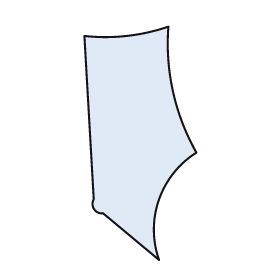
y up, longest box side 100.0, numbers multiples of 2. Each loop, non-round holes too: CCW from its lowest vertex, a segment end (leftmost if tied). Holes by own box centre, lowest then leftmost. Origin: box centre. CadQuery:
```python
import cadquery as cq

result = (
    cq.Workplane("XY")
    .moveTo(8.0, -50.0)
    .threePointArc((8.0, -24.0), (24.0, -4.0))
    .threePointArc((14.0, 22.0), (12.0, 50.0))
    .threePointArc((-6.0, 46.0), (-24.0, 46.0))
    .lineTo(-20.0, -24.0)
    .threePointArc((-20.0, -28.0), (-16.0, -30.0))
    .close()
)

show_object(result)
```